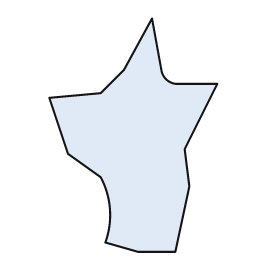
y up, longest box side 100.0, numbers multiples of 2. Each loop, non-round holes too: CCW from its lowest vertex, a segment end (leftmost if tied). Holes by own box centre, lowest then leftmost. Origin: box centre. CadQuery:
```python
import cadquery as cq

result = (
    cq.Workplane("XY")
    .moveTo(2.0, -50.0)
    .lineTo(18.0, -50.0)
    .lineTo(24.0, -22.0)
    .lineTo(22.0, -6.0)
    .lineTo(36.0, 22.0)
    .lineTo(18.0, 22.0)
    .threePointArc((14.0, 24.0), (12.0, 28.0))
    .lineTo(8.0, 50.0)
    .lineTo(-4.0, 28.0)
    .lineTo(-14.0, 18.0)
    .lineTo(-36.0, 16.0)
    .lineTo(-28.0, -8.0)
    .lineTo(-14.0, -18.0)
    .threePointArc((-10.0, -32.0), (-12.0, -46.0))
    .close()
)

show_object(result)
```